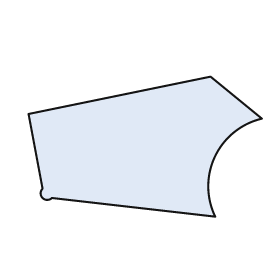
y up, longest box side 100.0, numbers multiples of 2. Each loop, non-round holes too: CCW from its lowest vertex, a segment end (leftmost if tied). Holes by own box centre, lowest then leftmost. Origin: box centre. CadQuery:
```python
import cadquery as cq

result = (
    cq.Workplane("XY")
    .moveTo(30.0, -30.0)
    .threePointArc((30.0, -4.0), (50.0, 12.0))
    .lineTo(28.0, 30.0)
    .lineTo(-50.0, 14.0)
    .lineTo(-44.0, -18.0)
    .threePointArc((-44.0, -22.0), (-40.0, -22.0))
    .close()
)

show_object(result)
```